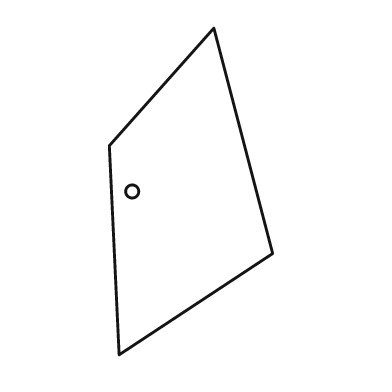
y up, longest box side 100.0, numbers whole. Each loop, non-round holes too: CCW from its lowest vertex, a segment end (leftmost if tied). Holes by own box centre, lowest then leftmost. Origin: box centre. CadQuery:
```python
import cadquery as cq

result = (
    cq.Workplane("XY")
    .moveTo(-22.0, -50.0)
    .lineTo(25.0, -19.0)
    .lineTo(7.0, 50.0)
    .lineTo(-25.0, 14.0)
    .close()
    .moveTo(-18.0, 0.0)
    .circle(2.0)
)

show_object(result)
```